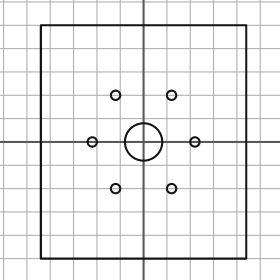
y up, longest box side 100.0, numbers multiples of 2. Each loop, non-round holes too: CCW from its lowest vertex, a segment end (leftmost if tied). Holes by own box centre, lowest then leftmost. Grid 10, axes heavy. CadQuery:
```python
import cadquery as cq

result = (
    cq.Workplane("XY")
    .moveTo(-44.0, -50.0)
    .lineTo(44.0, -50.0)
    .lineTo(44.0, 50.0)
    .lineTo(-44.0, 50.0)
    .close()
    .moveTo(-12.0, -20.0)
    .circle(2.0)
    .moveTo(12.0, -20.0)
    .circle(2.0)
    .moveTo(-22.0, 0.0)
    .circle(2.0)
    .moveTo(0.0, 0.0)
    .circle(8.0)
    .moveTo(22.0, 0.0)
    .circle(2.0)
    .moveTo(-12.0, 20.0)
    .circle(2.0)
    .moveTo(12.0, 20.0)
    .circle(2.0)
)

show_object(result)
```